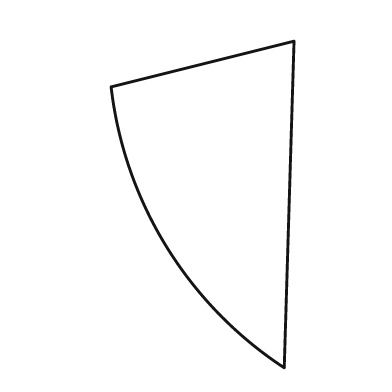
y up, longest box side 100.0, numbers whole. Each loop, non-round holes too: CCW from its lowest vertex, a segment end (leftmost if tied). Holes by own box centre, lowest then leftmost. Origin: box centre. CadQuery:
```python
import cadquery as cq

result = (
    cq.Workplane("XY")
    .moveTo(25.0, -50.0)
    .lineTo(28.0, 50.0)
    .lineTo(-28.0, 36.0)
    .threePointArc((-11.0, -13.0), (25.0, -50.0))
    .close()
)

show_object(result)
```